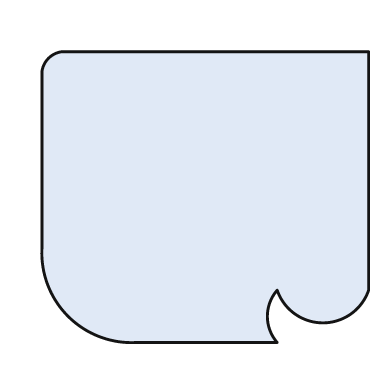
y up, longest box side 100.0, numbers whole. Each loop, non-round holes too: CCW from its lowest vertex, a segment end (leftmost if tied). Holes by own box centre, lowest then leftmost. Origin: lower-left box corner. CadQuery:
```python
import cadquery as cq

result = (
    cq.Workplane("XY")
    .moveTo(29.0, 0.0)
    .lineTo(72.0, 0.0)
    .threePointArc((69.0, 8.0), (72.0, 16.0))
    .threePointArc((86.0, 6.0), (100.0, 16.0))
    .lineTo(100.0, 89.0)
    .lineTo(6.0, 89.0)
    .threePointArc((2.0, 87.0), (0.0, 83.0))
    .lineTo(0.0, 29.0)
    .threePointArc((8.0, 8.0), (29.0, 0.0))
    .close()
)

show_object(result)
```